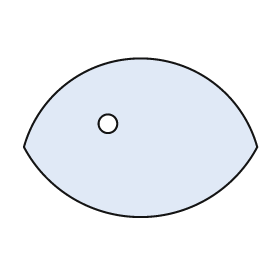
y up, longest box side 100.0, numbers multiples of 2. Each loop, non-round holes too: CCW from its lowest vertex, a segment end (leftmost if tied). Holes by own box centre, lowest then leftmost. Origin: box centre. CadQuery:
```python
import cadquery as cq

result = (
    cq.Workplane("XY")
    .moveTo(-50.0, -4.0)
    .threePointArc((0.0, -34.0), (50.0, -4.0))
    .threePointArc((0.0, 34.0), (-50.0, -4.0))
    .close()
    .moveTo(-14.0, 6.0)
    .circle(4.0)
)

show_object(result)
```